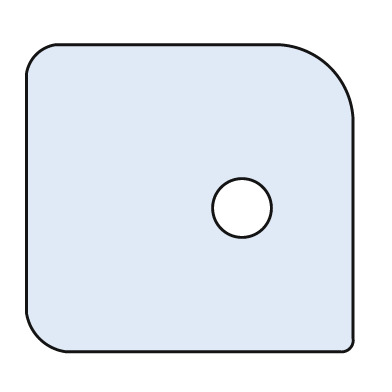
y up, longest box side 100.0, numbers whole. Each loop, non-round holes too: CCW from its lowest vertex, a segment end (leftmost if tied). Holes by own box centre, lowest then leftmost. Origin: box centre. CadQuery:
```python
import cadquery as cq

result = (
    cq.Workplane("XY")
    .moveTo(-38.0, -47.0)
    .lineTo(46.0, -47.0)
    .threePointArc((49.0, -46.0), (50.0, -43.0))
    .lineTo(50.0, 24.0)
    .threePointArc((43.0, 40.0), (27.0, 47.0))
    .lineTo(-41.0, 47.0)
    .threePointArc((-47.0, 44.0), (-50.0, 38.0))
    .lineTo(-50.0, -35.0)
    .threePointArc((-46.0, -43.0), (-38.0, -47.0))
    .close()
    .moveTo(16.0, -3.0)
    .circle(9.0)
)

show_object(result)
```